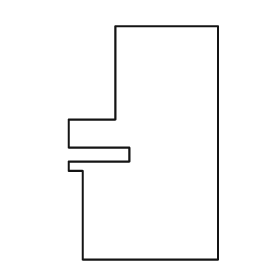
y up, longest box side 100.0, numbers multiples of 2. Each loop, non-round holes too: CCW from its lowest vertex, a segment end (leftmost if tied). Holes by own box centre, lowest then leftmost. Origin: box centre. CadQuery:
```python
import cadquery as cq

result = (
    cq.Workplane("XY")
    .moveTo(-26.0, -50.0)
    .lineTo(32.0, -50.0)
    .lineTo(32.0, 50.0)
    .lineTo(-12.0, 50.0)
    .lineTo(-12.0, 10.0)
    .lineTo(-32.0, 10.0)
    .lineTo(-32.0, -2.0)
    .lineTo(-6.0, -2.0)
    .lineTo(-6.0, -8.0)
    .lineTo(-32.0, -8.0)
    .lineTo(-32.0, -12.0)
    .lineTo(-26.0, -12.0)
    .close()
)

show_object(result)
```